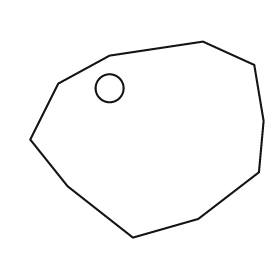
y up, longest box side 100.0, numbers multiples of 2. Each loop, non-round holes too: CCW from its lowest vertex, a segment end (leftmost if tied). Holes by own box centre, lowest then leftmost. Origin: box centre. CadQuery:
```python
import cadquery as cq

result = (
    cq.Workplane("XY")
    .moveTo(-6.0, -42.0)
    .lineTo(22.0, -34.0)
    .lineTo(48.0, -14.0)
    .lineTo(50.0, 8.0)
    .lineTo(46.0, 32.0)
    .lineTo(24.0, 42.0)
    .lineTo(-16.0, 36.0)
    .lineTo(-38.0, 24.0)
    .lineTo(-50.0, 0.0)
    .lineTo(-34.0, -20.0)
    .close()
    .moveTo(-16.0, 22.0)
    .circle(6.0)
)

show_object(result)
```